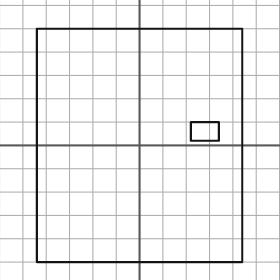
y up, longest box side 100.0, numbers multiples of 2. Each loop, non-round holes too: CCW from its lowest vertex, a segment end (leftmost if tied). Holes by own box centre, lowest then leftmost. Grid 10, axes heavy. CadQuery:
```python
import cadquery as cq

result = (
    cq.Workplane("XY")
    .moveTo(-44.0, -50.0)
    .lineTo(44.0, -50.0)
    .lineTo(44.0, 50.0)
    .lineTo(-44.0, 50.0)
    .close()
    .moveTo(22.0, 2.0)
    .lineTo(34.0, 2.0)
    .lineTo(34.0, 10.0)
    .lineTo(22.0, 10.0)
    .close()
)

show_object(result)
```